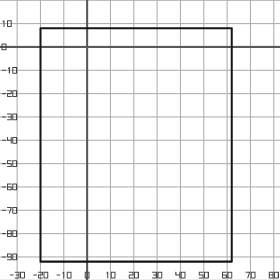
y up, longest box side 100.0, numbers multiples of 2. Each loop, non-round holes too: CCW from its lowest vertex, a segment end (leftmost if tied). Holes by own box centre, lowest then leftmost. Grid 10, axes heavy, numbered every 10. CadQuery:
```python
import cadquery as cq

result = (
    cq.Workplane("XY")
    .moveTo(-20.0, -92.0)
    .lineTo(62.0, -92.0)
    .lineTo(62.0, 8.0)
    .lineTo(-20.0, 8.0)
    .close()
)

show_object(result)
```